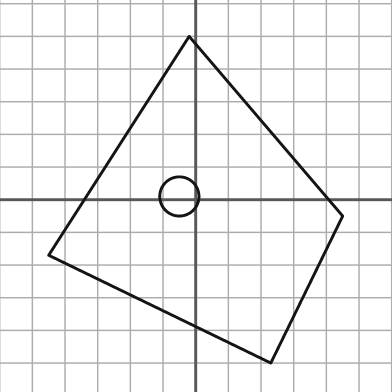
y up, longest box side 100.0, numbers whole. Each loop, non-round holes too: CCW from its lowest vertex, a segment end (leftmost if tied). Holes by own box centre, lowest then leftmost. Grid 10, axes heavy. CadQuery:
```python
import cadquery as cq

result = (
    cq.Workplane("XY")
    .moveTo(23.0, -50.0)
    .lineTo(45.0, -5.0)
    .lineTo(-2.0, 50.0)
    .lineTo(-45.0, -17.0)
    .close()
    .moveTo(-5.0, 1.0)
    .circle(6.0)
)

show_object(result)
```